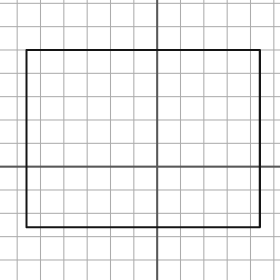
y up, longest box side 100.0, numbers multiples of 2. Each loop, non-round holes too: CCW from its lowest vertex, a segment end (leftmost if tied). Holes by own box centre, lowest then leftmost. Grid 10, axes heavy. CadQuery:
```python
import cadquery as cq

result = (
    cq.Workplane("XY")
    .moveTo(-56.0, -26.0)
    .lineTo(44.0, -26.0)
    .lineTo(44.0, 50.0)
    .lineTo(-56.0, 50.0)
    .close()
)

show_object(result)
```